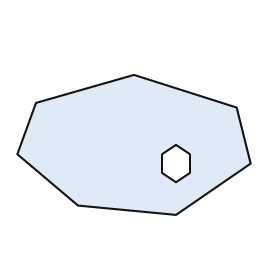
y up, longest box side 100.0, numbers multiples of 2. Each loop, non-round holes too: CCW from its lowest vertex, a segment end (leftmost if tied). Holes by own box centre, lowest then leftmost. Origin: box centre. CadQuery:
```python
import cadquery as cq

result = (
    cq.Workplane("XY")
    .moveTo(18.0, -30.0)
    .lineTo(50.0, -8.0)
    .lineTo(44.0, 16.0)
    .lineTo(0.0, 30.0)
    .lineTo(-42.0, 18.0)
    .lineTo(-50.0, -4.0)
    .lineTo(-24.0, -26.0)
    .close()
    .moveTo(18.0, -16.0)
    .lineTo(24.0, -12.0)
    .lineTo(24.0, -4.0)
    .lineTo(18.0, 0.0)
    .lineTo(12.0, -4.0)
    .lineTo(12.0, -12.0)
    .close()
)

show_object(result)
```